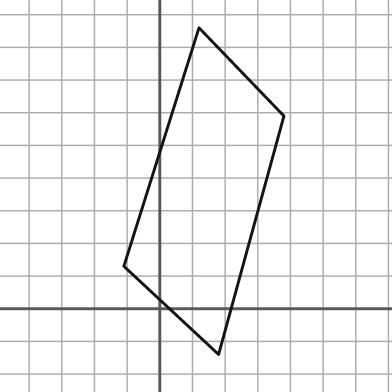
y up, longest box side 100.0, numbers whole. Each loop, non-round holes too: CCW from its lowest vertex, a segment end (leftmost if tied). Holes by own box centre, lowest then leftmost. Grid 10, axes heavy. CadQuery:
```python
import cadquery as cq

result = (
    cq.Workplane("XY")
    .moveTo(18.0, -14.0)
    .lineTo(38.0, 59.0)
    .lineTo(12.0, 86.0)
    .lineTo(-11.0, 13.0)
    .close()
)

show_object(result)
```